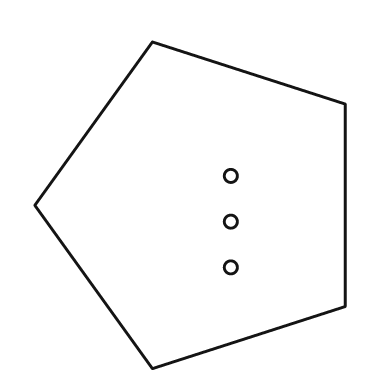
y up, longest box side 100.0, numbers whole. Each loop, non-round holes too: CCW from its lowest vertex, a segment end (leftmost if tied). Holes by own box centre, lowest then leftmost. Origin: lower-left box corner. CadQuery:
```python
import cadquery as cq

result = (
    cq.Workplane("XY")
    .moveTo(36.0, 0.0)
    .lineTo(95.0, 19.0)
    .lineTo(95.0, 81.0)
    .lineTo(36.0, 100.0)
    .lineTo(0.0, 50.0)
    .close()
    .moveTo(60.0, 31.0)
    .circle(2.0)
    .moveTo(60.0, 45.0)
    .circle(2.0)
    .moveTo(60.0, 59.0)
    .circle(2.0)
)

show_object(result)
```